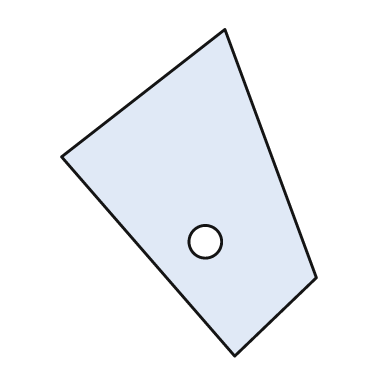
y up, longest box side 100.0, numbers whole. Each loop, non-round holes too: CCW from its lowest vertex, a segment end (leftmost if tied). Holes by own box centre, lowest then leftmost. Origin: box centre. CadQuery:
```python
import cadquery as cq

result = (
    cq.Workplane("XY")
    .moveTo(14.0, -50.0)
    .lineTo(39.0, -26.0)
    .lineTo(11.0, 50.0)
    .lineTo(-39.0, 11.0)
    .close()
    .moveTo(5.0, -15.0)
    .circle(5.0)
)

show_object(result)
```